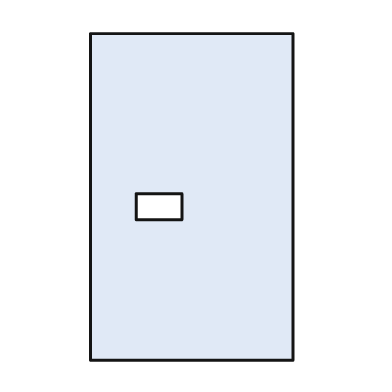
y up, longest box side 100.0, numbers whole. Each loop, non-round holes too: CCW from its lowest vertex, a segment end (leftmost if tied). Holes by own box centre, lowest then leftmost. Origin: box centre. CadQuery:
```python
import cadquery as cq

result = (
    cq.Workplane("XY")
    .moveTo(-31.0, -50.0)
    .lineTo(31.0, -50.0)
    .lineTo(31.0, 50.0)
    .lineTo(-31.0, 50.0)
    .close()
    .moveTo(-17.0, -7.0)
    .lineTo(-3.0, -7.0)
    .lineTo(-3.0, 1.0)
    .lineTo(-17.0, 1.0)
    .close()
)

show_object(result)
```